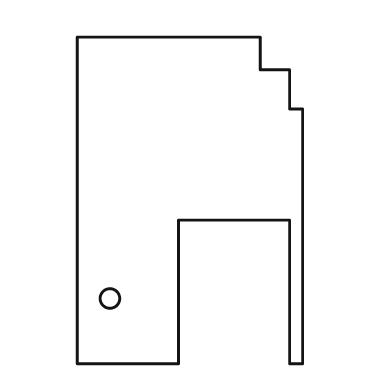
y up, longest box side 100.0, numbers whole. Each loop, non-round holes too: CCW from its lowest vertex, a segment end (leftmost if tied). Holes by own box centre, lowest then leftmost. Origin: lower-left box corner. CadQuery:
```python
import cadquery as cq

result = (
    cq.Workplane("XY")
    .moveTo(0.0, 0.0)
    .lineTo(31.0, 0.0)
    .lineTo(31.0, 44.0)
    .lineTo(65.0, 44.0)
    .lineTo(65.0, 0.0)
    .lineTo(69.0, 0.0)
    .lineTo(69.0, 78.0)
    .lineTo(65.0, 78.0)
    .lineTo(65.0, 90.0)
    .lineTo(56.0, 90.0)
    .lineTo(56.0, 100.0)
    .lineTo(0.0, 100.0)
    .close()
    .moveTo(10.0, 20.0)
    .circle(3.0)
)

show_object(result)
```